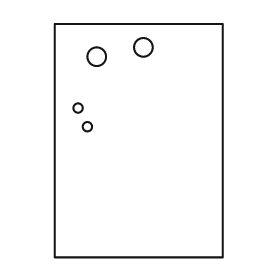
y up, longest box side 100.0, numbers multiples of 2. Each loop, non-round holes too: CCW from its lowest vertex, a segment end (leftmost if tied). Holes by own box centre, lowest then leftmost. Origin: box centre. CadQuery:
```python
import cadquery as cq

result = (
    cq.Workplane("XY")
    .moveTo(-36.0, -50.0)
    .lineTo(36.0, -50.0)
    .lineTo(36.0, 50.0)
    .lineTo(-36.0, 50.0)
    .close()
    .moveTo(-22.0, 6.0)
    .circle(2.0)
    .moveTo(-26.0, 14.0)
    .circle(2.0)
    .moveTo(-18.0, 36.0)
    .circle(4.0)
    .moveTo(2.0, 40.0)
    .circle(4.0)
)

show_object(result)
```